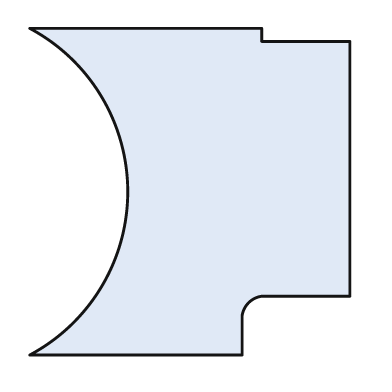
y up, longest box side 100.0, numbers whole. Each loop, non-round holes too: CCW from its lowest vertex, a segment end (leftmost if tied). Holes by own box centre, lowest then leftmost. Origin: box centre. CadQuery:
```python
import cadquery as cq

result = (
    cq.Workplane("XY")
    .moveTo(-49.0, -50.0)
    .lineTo(16.0, -50.0)
    .lineTo(16.0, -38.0)
    .threePointArc((18.0, -34.0), (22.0, -32.0))
    .lineTo(49.0, -32.0)
    .lineTo(49.0, 46.0)
    .lineTo(22.0, 46.0)
    .lineTo(22.0, 50.0)
    .lineTo(-49.0, 50.0)
    .threePointArc((-19.0, 0.0), (-49.0, -50.0))
    .close()
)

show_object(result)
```